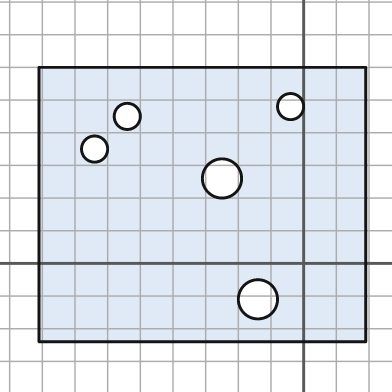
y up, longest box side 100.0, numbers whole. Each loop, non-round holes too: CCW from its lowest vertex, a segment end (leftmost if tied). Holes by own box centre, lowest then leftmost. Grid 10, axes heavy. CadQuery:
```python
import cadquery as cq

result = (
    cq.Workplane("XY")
    .moveTo(-81.0, -24.0)
    .lineTo(19.0, -24.0)
    .lineTo(19.0, 60.0)
    .lineTo(-81.0, 60.0)
    .close()
    .moveTo(-14.0, -11.0)
    .circle(6.0)
    .moveTo(-25.0, 26.0)
    .circle(6.0)
    .moveTo(-64.0, 35.0)
    .circle(4.0)
    .moveTo(-54.0, 45.0)
    .circle(4.0)
    .moveTo(-4.0, 48.0)
    .circle(4.0)
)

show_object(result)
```